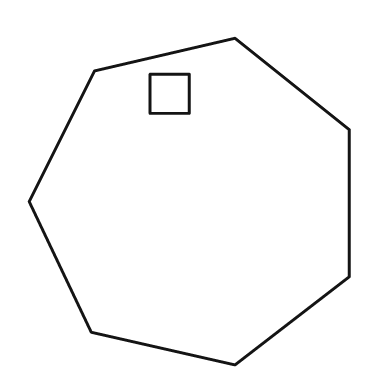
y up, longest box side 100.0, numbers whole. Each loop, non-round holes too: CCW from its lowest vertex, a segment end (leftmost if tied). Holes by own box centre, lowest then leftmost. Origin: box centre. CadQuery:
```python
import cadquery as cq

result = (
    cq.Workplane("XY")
    .moveTo(14.0, -50.0)
    .lineTo(49.0, -23.0)
    .lineTo(49.0, 22.0)
    .lineTo(14.0, 50.0)
    .lineTo(-29.0, 40.0)
    .lineTo(-49.0, 0.0)
    .lineTo(-30.0, -40.0)
    .close()
    .moveTo(-12.0, 27.0)
    .lineTo(0.0, 27.0)
    .lineTo(0.0, 39.0)
    .lineTo(-12.0, 39.0)
    .close()
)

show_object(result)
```